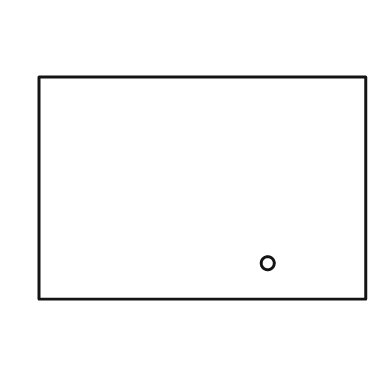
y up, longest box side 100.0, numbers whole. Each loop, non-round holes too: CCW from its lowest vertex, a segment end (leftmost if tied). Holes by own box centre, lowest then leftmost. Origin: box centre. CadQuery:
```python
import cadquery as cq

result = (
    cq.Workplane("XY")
    .moveTo(-50.0, -34.0)
    .lineTo(50.0, -34.0)
    .lineTo(50.0, 34.0)
    .lineTo(-50.0, 34.0)
    .close()
    .moveTo(20.0, -23.0)
    .circle(2.0)
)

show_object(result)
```